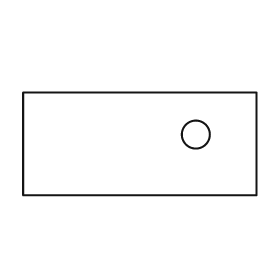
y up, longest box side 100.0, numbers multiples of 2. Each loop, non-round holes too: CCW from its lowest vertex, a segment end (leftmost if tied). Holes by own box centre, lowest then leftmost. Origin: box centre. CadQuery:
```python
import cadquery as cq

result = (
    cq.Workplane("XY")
    .moveTo(-50.0, -22.0)
    .lineTo(50.0, -22.0)
    .lineTo(50.0, 22.0)
    .lineTo(-50.0, 22.0)
    .close()
    .moveTo(24.0, 4.0)
    .circle(6.0)
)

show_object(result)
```